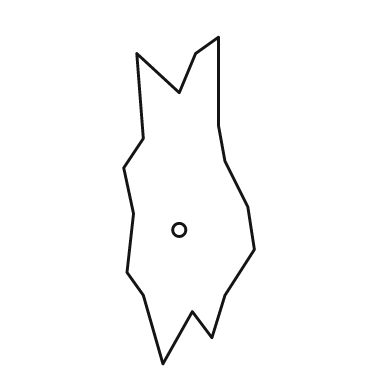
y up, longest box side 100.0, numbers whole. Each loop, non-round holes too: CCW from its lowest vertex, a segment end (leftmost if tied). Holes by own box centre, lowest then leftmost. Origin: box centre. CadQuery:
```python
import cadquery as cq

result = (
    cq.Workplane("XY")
    .moveTo(-8.0, -50.0)
    .lineTo(1.0, -34.0)
    .lineTo(7.0, -42.0)
    .lineTo(11.0, -29.0)
    .lineTo(20.0, -15.0)
    .lineTo(18.0, -2.0)
    .lineTo(11.0, 12.0)
    .lineTo(9.0, 23.0)
    .lineTo(9.0, 50.0)
    .lineTo(2.0, 45.0)
    .lineTo(-3.0, 33.0)
    .lineTo(-16.0, 45.0)
    .lineTo(-14.0, 19.0)
    .lineTo(-20.0, 10.0)
    .lineTo(-17.0, -4.0)
    .lineTo(-19.0, -22.0)
    .lineTo(-14.0, -29.0)
    .close()
    .moveTo(-3.0, -9.0)
    .circle(2.0)
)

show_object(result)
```